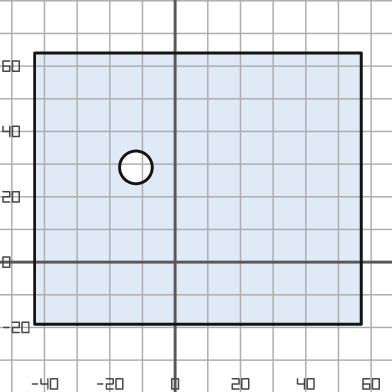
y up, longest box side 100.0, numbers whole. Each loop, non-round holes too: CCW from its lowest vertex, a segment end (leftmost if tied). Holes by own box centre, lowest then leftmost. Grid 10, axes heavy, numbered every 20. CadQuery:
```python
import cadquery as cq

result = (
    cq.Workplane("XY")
    .moveTo(-43.0, -19.0)
    .lineTo(57.0, -19.0)
    .lineTo(57.0, 64.0)
    .lineTo(-43.0, 64.0)
    .close()
    .moveTo(-12.0, 29.0)
    .circle(5.0)
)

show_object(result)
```